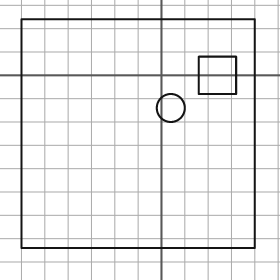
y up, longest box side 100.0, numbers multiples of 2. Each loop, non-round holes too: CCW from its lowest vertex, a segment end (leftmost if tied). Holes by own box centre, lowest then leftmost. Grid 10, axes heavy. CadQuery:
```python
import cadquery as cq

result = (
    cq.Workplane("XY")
    .moveTo(-60.0, -74.0)
    .lineTo(40.0, -74.0)
    .lineTo(40.0, 24.0)
    .lineTo(-60.0, 24.0)
    .close()
    .moveTo(4.0, -14.0)
    .circle(6.0)
    .moveTo(16.0, -8.0)
    .lineTo(32.0, -8.0)
    .lineTo(32.0, 8.0)
    .lineTo(16.0, 8.0)
    .close()
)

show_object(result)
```